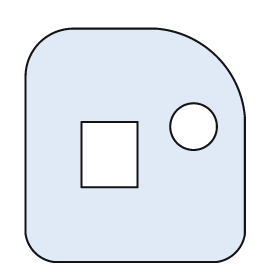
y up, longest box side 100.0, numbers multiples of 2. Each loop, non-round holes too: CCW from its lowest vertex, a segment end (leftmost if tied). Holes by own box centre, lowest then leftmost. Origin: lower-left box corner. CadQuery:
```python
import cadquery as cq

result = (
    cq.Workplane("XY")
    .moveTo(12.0, 0.0)
    .lineTo(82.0, 0.0)
    .threePointArc((90.0, 4.0), (94.0, 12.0))
    .lineTo(94.0, 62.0)
    .threePointArc((82.0, 88.0), (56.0, 100.0))
    .lineTo(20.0, 100.0)
    .threePointArc((6.0, 94.0), (0.0, 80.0))
    .lineTo(0.0, 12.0)
    .threePointArc((4.0, 4.0), (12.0, 0.0))
    .close()
    .moveTo(24.0, 32.0)
    .lineTo(48.0, 32.0)
    .lineTo(48.0, 60.0)
    .lineTo(24.0, 60.0)
    .close()
    .moveTo(72.0, 58.0)
    .circle(10.0)
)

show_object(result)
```